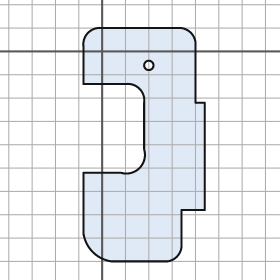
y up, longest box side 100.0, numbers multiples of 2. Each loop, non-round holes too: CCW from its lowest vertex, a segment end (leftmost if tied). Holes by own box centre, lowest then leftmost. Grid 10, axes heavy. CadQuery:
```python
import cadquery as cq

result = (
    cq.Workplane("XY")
    .moveTo(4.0, -90.0)
    .lineTo(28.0, -90.0)
    .threePointArc((32.0, -88.0), (34.0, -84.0))
    .lineTo(34.0, -68.0)
    .lineTo(44.0, -68.0)
    .lineTo(44.0, -22.0)
    .lineTo(40.0, -22.0)
    .lineTo(40.0, 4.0)
    .threePointArc((38.0, 8.0), (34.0, 10.0))
    .lineTo(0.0, 10.0)
    .threePointArc((-6.0, 8.0), (-8.0, 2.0))
    .lineTo(-8.0, -14.0)
    .lineTo(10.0, -14.0)
    .threePointArc((16.0, -16.0), (18.0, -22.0))
    .lineTo(18.0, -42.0)
    .threePointArc((16.0, -50.0), (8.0, -52.0))
    .lineTo(-8.0, -52.0)
    .lineTo(-8.0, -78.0)
    .threePointArc((-4.0, -86.0), (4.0, -90.0))
    .close()
    .moveTo(20.0, -6.0)
    .circle(2.0)
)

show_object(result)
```